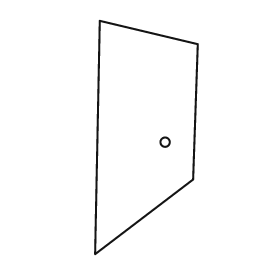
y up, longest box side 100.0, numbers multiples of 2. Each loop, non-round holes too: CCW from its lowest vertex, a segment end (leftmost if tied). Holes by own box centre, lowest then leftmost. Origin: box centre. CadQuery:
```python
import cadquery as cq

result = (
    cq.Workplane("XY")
    .moveTo(-22.0, -50.0)
    .lineTo(20.0, -18.0)
    .lineTo(22.0, 40.0)
    .lineTo(-20.0, 50.0)
    .close()
    .moveTo(8.0, -2.0)
    .circle(2.0)
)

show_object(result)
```